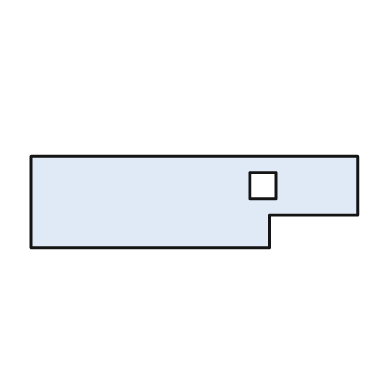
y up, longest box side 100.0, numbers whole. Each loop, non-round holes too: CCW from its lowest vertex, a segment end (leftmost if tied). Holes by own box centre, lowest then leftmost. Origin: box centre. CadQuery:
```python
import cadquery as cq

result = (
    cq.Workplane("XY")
    .moveTo(-50.0, -14.0)
    .lineTo(23.0, -14.0)
    .lineTo(23.0, -4.0)
    .lineTo(50.0, -4.0)
    .lineTo(50.0, 14.0)
    .lineTo(-50.0, 14.0)
    .close()
    .moveTo(17.0, 1.0)
    .lineTo(25.0, 1.0)
    .lineTo(25.0, 9.0)
    .lineTo(17.0, 9.0)
    .close()
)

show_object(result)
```